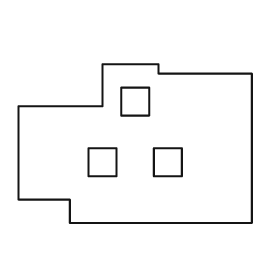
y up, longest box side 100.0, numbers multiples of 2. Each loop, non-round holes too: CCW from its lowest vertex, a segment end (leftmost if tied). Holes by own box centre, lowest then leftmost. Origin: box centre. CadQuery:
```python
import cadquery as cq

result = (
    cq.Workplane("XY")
    .moveTo(-28.0, -34.0)
    .lineTo(50.0, -34.0)
    .lineTo(50.0, 30.0)
    .lineTo(10.0, 30.0)
    .lineTo(10.0, 34.0)
    .lineTo(-14.0, 34.0)
    .lineTo(-14.0, 16.0)
    .lineTo(-50.0, 16.0)
    .lineTo(-50.0, -24.0)
    .lineTo(-28.0, -24.0)
    .close()
    .moveTo(-20.0, -14.0)
    .lineTo(-8.0, -14.0)
    .lineTo(-8.0, -2.0)
    .lineTo(-20.0, -2.0)
    .close()
    .moveTo(8.0, -14.0)
    .lineTo(20.0, -14.0)
    .lineTo(20.0, -2.0)
    .lineTo(8.0, -2.0)
    .close()
    .moveTo(-6.0, 12.0)
    .lineTo(6.0, 12.0)
    .lineTo(6.0, 24.0)
    .lineTo(-6.0, 24.0)
    .close()
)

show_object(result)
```